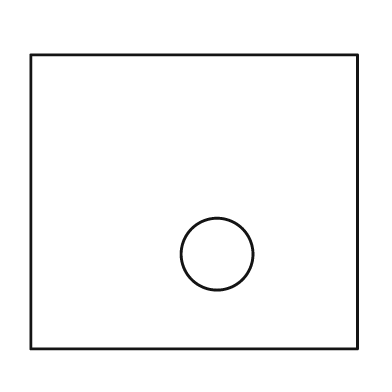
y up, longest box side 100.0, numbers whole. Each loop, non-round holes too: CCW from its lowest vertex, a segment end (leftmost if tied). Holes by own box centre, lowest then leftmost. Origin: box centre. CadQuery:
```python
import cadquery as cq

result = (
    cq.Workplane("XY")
    .moveTo(-50.0, -45.0)
    .lineTo(50.0, -45.0)
    .lineTo(50.0, 45.0)
    .lineTo(-50.0, 45.0)
    .close()
    .moveTo(7.0, -16.0)
    .circle(11.0)
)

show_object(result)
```